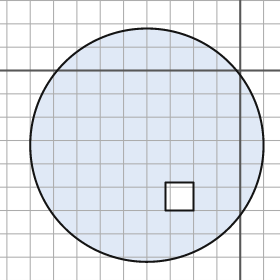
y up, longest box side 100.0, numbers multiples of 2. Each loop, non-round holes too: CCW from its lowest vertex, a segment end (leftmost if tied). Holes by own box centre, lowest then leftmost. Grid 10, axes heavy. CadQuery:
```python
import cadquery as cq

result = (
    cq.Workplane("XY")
    .moveTo(-40.0, -32.0)
    .circle(50.0)
    .moveTo(-32.0, -60.0)
    .lineTo(-20.0, -60.0)
    .lineTo(-20.0, -48.0)
    .lineTo(-32.0, -48.0)
    .close()
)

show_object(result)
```